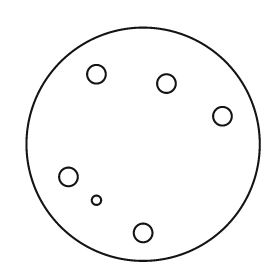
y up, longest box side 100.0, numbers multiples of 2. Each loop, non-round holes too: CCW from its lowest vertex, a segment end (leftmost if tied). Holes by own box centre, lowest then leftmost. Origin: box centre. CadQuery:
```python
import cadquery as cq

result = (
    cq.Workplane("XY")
    .moveTo(0.0, 0.0)
    .circle(50.0)
    .moveTo(0.0, -38.0)
    .circle(4.0)
    .moveTo(-20.0, -24.0)
    .circle(2.0)
    .moveTo(-32.0, -14.0)
    .circle(4.0)
    .moveTo(34.0, 12.0)
    .circle(4.0)
    .moveTo(10.0, 26.0)
    .circle(4.0)
    .moveTo(-20.0, 30.0)
    .circle(4.0)
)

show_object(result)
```